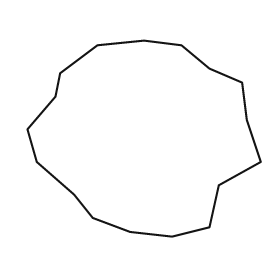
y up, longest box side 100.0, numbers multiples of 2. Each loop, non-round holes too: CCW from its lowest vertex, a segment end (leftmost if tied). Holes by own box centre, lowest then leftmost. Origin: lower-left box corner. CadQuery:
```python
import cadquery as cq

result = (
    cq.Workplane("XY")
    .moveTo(62.0, 0.0)
    .lineTo(78.0, 4.0)
    .lineTo(82.0, 22.0)
    .lineTo(100.0, 32.0)
    .lineTo(94.0, 50.0)
    .lineTo(92.0, 66.0)
    .lineTo(78.0, 72.0)
    .lineTo(66.0, 82.0)
    .lineTo(50.0, 84.0)
    .lineTo(30.0, 82.0)
    .lineTo(14.0, 70.0)
    .lineTo(12.0, 60.0)
    .lineTo(0.0, 46.0)
    .lineTo(4.0, 32.0)
    .lineTo(20.0, 18.0)
    .lineTo(28.0, 8.0)
    .lineTo(44.0, 2.0)
    .close()
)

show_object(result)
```